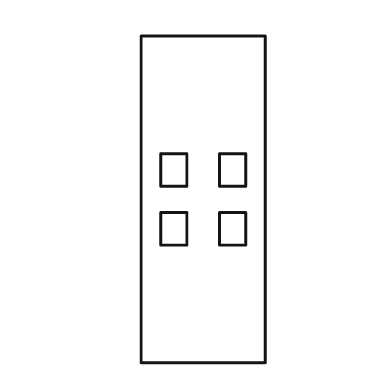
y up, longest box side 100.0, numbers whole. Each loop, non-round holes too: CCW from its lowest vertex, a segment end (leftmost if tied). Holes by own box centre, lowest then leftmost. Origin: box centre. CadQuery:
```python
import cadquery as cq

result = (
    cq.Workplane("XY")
    .moveTo(-19.0, -50.0)
    .lineTo(19.0, -50.0)
    .lineTo(19.0, 50.0)
    .lineTo(-19.0, 50.0)
    .close()
    .moveTo(-13.0, -14.0)
    .lineTo(-5.0, -14.0)
    .lineTo(-5.0, -4.0)
    .lineTo(-13.0, -4.0)
    .close()
    .moveTo(5.0, -14.0)
    .lineTo(13.0, -14.0)
    .lineTo(13.0, -4.0)
    .lineTo(5.0, -4.0)
    .close()
    .moveTo(-13.0, 4.0)
    .lineTo(-5.0, 4.0)
    .lineTo(-5.0, 14.0)
    .lineTo(-13.0, 14.0)
    .close()
    .moveTo(5.0, 4.0)
    .lineTo(13.0, 4.0)
    .lineTo(13.0, 14.0)
    .lineTo(5.0, 14.0)
    .close()
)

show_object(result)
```